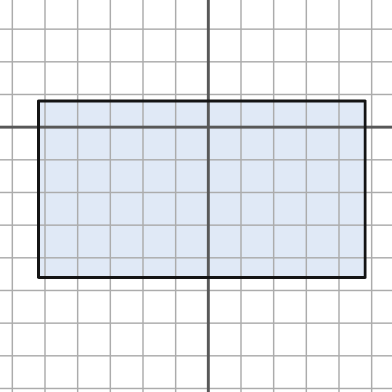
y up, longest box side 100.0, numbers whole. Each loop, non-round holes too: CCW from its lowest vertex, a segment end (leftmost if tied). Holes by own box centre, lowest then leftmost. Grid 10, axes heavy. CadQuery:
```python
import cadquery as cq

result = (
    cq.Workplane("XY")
    .moveTo(-52.0, -46.0)
    .lineTo(48.0, -46.0)
    .lineTo(48.0, 8.0)
    .lineTo(-52.0, 8.0)
    .close()
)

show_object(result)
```